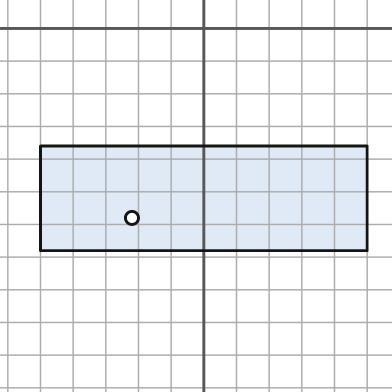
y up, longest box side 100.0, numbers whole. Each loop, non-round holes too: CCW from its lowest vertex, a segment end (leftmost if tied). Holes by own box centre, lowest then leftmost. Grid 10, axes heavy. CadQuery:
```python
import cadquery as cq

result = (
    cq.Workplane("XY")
    .moveTo(-50.0, -68.0)
    .lineTo(50.0, -68.0)
    .lineTo(50.0, -36.0)
    .lineTo(-50.0, -36.0)
    .close()
    .moveTo(-22.0, -58.0)
    .circle(2.0)
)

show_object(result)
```